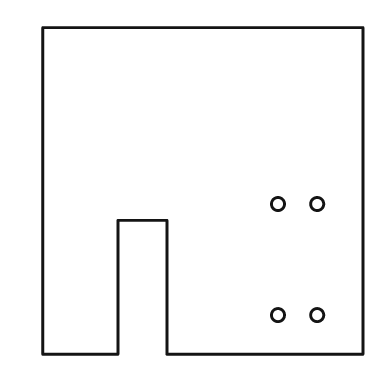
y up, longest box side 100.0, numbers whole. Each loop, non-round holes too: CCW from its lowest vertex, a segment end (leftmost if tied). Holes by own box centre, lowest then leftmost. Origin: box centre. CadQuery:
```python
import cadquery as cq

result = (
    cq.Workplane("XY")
    .moveTo(-49.0, -50.0)
    .lineTo(-26.0, -50.0)
    .lineTo(-26.0, -9.0)
    .lineTo(-11.0, -9.0)
    .lineTo(-11.0, -50.0)
    .lineTo(49.0, -50.0)
    .lineTo(49.0, 50.0)
    .lineTo(-49.0, 50.0)
    .close()
    .moveTo(23.0, -38.0)
    .circle(2.0)
    .moveTo(35.0, -38.0)
    .circle(2.0)
    .moveTo(23.0, -4.0)
    .circle(2.0)
    .moveTo(35.0, -4.0)
    .circle(2.0)
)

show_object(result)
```